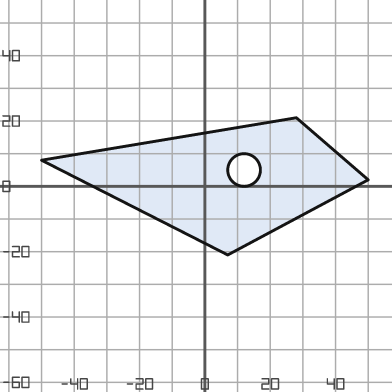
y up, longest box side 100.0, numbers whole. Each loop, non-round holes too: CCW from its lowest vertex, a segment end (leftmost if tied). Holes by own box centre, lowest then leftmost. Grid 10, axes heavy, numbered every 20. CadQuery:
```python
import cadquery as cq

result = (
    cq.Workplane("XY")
    .moveTo(7.0, -21.0)
    .lineTo(50.0, 2.0)
    .lineTo(28.0, 21.0)
    .lineTo(-50.0, 8.0)
    .close()
    .moveTo(12.0, 5.0)
    .circle(5.0)
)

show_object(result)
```